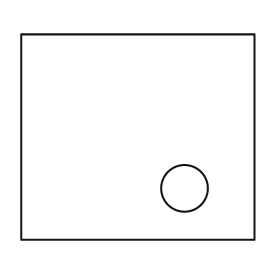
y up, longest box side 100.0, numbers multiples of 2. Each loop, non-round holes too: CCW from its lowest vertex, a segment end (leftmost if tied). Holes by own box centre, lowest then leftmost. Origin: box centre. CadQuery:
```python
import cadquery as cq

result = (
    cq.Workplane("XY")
    .moveTo(-50.0, -44.0)
    .lineTo(50.0, -44.0)
    .lineTo(50.0, 44.0)
    .lineTo(-50.0, 44.0)
    .close()
    .moveTo(20.0, -22.0)
    .circle(10.0)
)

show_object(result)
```